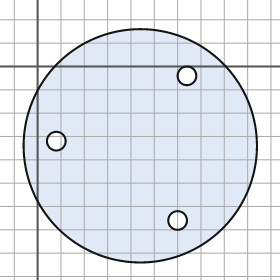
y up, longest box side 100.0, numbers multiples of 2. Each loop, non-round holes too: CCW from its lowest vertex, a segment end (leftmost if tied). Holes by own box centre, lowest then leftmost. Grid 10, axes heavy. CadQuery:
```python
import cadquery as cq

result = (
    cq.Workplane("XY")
    .moveTo(44.0, -34.0)
    .circle(50.0)
    .moveTo(60.0, -66.0)
    .circle(4.0)
    .moveTo(8.0, -32.0)
    .circle(4.0)
    .moveTo(64.0, -4.0)
    .circle(4.0)
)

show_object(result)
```